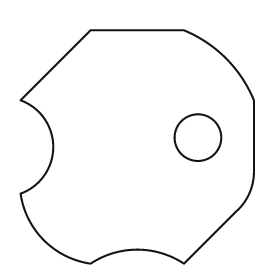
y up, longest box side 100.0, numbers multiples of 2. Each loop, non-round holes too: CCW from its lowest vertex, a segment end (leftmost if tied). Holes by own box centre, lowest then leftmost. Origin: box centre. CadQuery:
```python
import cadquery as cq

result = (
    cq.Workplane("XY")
    .moveTo(-20.0, -50.0)
    .threePointArc((0.0, -44.0), (20.0, -50.0))
    .lineTo(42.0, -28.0)
    .threePointArc((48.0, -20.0), (50.0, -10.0))
    .lineTo(50.0, 20.0)
    .threePointArc((38.0, 38.0), (20.0, 50.0))
    .lineTo(-20.0, 50.0)
    .lineTo(-50.0, 20.0)
    .threePointArc((-36.0, 0.0), (-50.0, -20.0))
    .threePointArc((-40.0, -40.0), (-20.0, -50.0))
    .close()
    .moveTo(26.0, 4.0)
    .circle(10.0)
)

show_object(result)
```